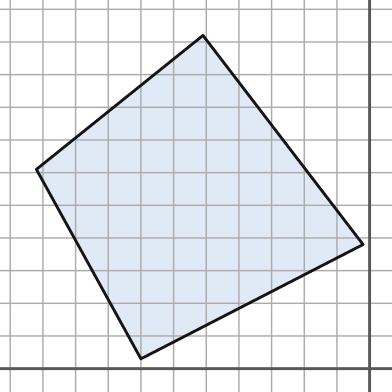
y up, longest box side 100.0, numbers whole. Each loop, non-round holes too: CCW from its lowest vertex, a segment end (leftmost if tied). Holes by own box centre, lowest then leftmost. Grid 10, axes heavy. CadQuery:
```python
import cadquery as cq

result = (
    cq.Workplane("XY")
    .moveTo(-70.0, 3.0)
    .lineTo(-2.0, 38.0)
    .lineTo(-51.0, 102.0)
    .lineTo(-102.0, 61.0)
    .close()
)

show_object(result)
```